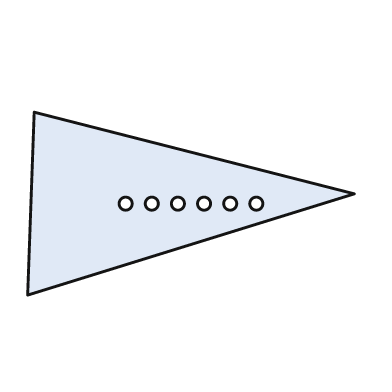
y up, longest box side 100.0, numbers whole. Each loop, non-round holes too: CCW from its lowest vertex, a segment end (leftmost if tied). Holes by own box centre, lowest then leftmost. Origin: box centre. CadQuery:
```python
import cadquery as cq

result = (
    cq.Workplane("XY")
    .moveTo(-50.0, -28.0)
    .lineTo(50.0, 3.0)
    .lineTo(-48.0, 28.0)
    .close()
    .moveTo(-20.0, 0.0)
    .circle(2.0)
    .moveTo(-12.0, 0.0)
    .circle(2.0)
    .moveTo(-4.0, 0.0)
    .circle(2.0)
    .moveTo(4.0, 0.0)
    .circle(2.0)
    .moveTo(12.0, 0.0)
    .circle(2.0)
    .moveTo(20.0, 0.0)
    .circle(2.0)
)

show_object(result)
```